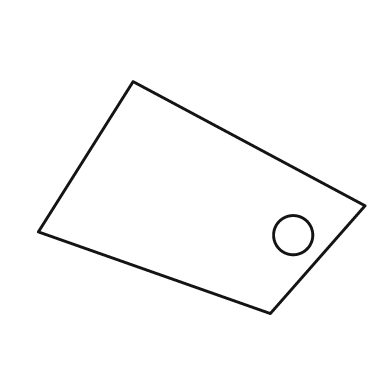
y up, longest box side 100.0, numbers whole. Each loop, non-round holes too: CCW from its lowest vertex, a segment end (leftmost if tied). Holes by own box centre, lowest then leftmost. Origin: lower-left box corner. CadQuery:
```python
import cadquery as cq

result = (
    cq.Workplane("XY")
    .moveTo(71.0, 0.0)
    .lineTo(100.0, 33.0)
    .lineTo(29.0, 71.0)
    .lineTo(0.0, 25.0)
    .close()
    .moveTo(78.0, 24.0)
    .circle(6.0)
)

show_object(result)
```